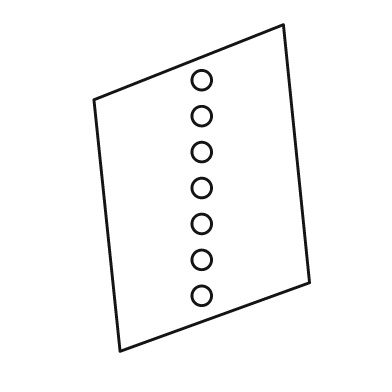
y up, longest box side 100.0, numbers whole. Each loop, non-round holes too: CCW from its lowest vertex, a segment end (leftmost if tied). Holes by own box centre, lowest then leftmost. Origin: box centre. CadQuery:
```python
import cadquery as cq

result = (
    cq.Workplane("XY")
    .moveTo(-25.0, -50.0)
    .lineTo(33.0, -29.0)
    .lineTo(25.0, 50.0)
    .lineTo(-33.0, 27.0)
    .close()
    .moveTo(0.0, -33.0)
    .circle(3.0)
    .moveTo(0.0, -22.0)
    .circle(3.0)
    .moveTo(0.0, -11.0)
    .circle(3.0)
    .moveTo(0.0, 0.0)
    .circle(3.0)
    .moveTo(0.0, 11.0)
    .circle(3.0)
    .moveTo(0.0, 22.0)
    .circle(3.0)
    .moveTo(0.0, 33.0)
    .circle(3.0)
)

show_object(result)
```